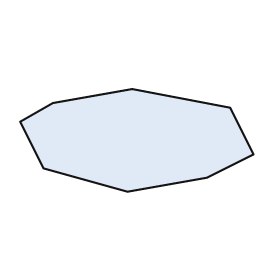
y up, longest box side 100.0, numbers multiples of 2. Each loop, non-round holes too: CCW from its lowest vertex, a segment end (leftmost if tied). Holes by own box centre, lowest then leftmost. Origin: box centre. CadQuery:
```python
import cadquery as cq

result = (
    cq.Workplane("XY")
    .moveTo(-4.0, -22.0)
    .lineTo(30.0, -16.0)
    .lineTo(50.0, -6.0)
    .lineTo(40.0, 14.0)
    .lineTo(-2.0, 22.0)
    .lineTo(-36.0, 16.0)
    .lineTo(-50.0, 8.0)
    .lineTo(-40.0, -12.0)
    .close()
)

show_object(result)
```